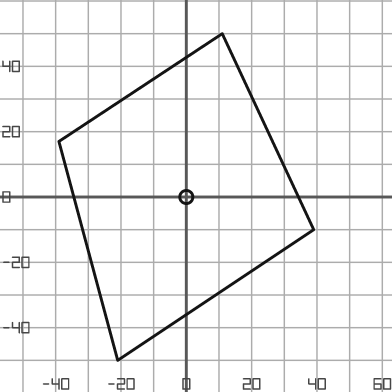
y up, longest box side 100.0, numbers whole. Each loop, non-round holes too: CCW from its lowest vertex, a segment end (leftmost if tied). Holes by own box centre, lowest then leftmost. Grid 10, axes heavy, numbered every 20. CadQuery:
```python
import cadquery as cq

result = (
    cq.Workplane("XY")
    .moveTo(-21.0, -50.0)
    .lineTo(39.0, -10.0)
    .lineTo(11.0, 50.0)
    .lineTo(-39.0, 17.0)
    .close()
    .moveTo(0.0, 0.0)
    .circle(2.0)
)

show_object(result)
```